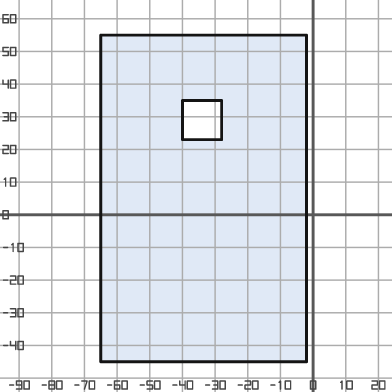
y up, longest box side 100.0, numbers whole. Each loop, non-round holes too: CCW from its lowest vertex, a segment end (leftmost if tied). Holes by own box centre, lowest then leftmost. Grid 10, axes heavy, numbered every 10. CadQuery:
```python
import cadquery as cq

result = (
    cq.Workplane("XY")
    .moveTo(-65.0, -45.0)
    .lineTo(-2.0, -45.0)
    .lineTo(-2.0, 55.0)
    .lineTo(-65.0, 55.0)
    .close()
    .moveTo(-40.0, 23.0)
    .lineTo(-28.0, 23.0)
    .lineTo(-28.0, 35.0)
    .lineTo(-40.0, 35.0)
    .close()
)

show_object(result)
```